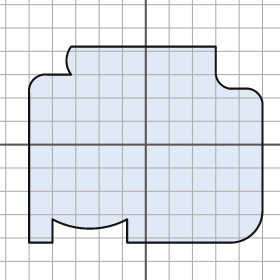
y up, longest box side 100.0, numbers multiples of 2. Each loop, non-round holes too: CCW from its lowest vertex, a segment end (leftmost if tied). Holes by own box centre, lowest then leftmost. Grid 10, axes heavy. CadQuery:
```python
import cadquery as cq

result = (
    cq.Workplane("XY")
    .moveTo(-50.0, -42.0)
    .lineTo(-40.0, -42.0)
    .lineTo(-40.0, -32.0)
    .threePointArc((-24.0, -36.0), (-8.0, -32.0))
    .lineTo(-8.0, -42.0)
    .lineTo(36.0, -42.0)
    .threePointArc((46.0, -38.0), (50.0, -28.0))
    .lineTo(50.0, 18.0)
    .threePointArc((48.0, 22.0), (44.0, 24.0))
    .lineTo(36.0, 24.0)
    .threePointArc((32.0, 26.0), (30.0, 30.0))
    .lineTo(30.0, 42.0)
    .lineTo(-32.0, 42.0)
    .threePointArc((-34.0, 36.0), (-32.0, 30.0))
    .lineTo(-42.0, 30.0)
    .threePointArc((-48.0, 28.0), (-50.0, 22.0))
    .close()
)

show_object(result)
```